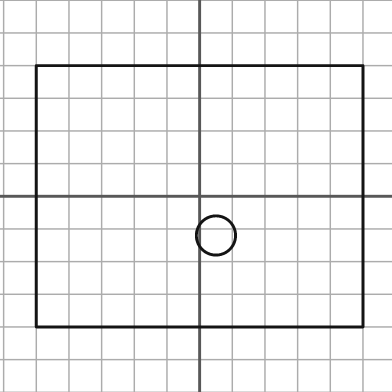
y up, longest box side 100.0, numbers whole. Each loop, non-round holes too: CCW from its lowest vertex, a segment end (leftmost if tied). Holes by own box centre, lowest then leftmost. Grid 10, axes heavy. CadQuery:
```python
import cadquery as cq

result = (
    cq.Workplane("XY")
    .moveTo(-50.0, -40.0)
    .lineTo(50.0, -40.0)
    .lineTo(50.0, 40.0)
    .lineTo(-50.0, 40.0)
    .close()
    .moveTo(5.0, -12.0)
    .circle(6.0)
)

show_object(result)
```